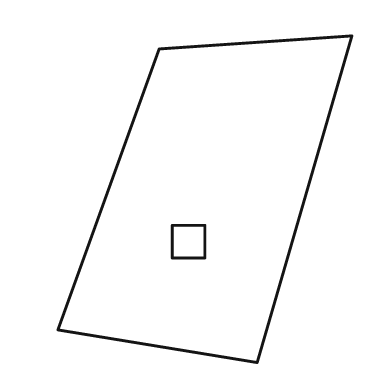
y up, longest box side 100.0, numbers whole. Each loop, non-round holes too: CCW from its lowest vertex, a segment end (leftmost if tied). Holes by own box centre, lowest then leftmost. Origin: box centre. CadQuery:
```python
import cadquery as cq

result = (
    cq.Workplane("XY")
    .moveTo(16.0, -50.0)
    .lineTo(45.0, 50.0)
    .lineTo(-14.0, 46.0)
    .lineTo(-45.0, -40.0)
    .close()
    .moveTo(-10.0, -18.0)
    .lineTo(0.0, -18.0)
    .lineTo(0.0, -8.0)
    .lineTo(-10.0, -8.0)
    .close()
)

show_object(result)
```